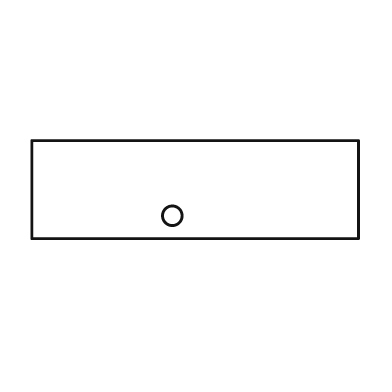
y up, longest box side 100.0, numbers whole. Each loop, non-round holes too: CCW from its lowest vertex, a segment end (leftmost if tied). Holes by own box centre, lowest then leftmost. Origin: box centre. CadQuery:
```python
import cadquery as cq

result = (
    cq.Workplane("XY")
    .moveTo(-50.0, -15.0)
    .lineTo(50.0, -15.0)
    .lineTo(50.0, 15.0)
    .lineTo(-50.0, 15.0)
    .close()
    .moveTo(-7.0, -8.0)
    .circle(3.0)
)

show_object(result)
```